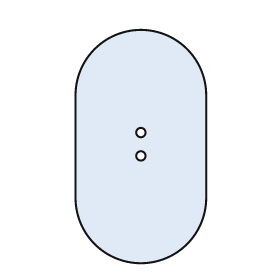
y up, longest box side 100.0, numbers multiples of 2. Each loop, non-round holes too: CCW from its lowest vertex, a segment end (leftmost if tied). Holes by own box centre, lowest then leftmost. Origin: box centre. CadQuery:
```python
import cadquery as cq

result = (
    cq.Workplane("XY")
    .moveTo(-28.0, -22.0)
    .threePointArc((0.0, -50.0), (28.0, -22.0))
    .lineTo(28.0, 22.0)
    .threePointArc((0.0, 50.0), (-28.0, 22.0))
    .close()
    .moveTo(0.0, -4.0)
    .circle(2.0)
    .moveTo(0.0, 6.0)
    .circle(2.0)
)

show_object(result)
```